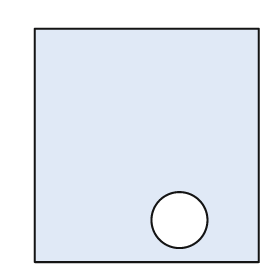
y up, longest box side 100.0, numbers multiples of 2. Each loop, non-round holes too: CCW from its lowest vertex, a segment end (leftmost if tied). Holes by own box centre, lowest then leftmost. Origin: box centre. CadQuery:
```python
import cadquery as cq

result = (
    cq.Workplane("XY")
    .moveTo(-48.0, -50.0)
    .lineTo(48.0, -50.0)
    .lineTo(48.0, 50.0)
    .lineTo(-48.0, 50.0)
    .close()
    .moveTo(14.0, -32.0)
    .circle(12.0)
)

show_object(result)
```